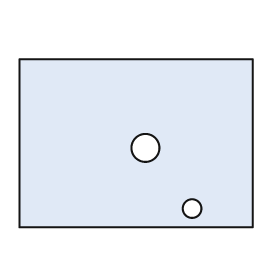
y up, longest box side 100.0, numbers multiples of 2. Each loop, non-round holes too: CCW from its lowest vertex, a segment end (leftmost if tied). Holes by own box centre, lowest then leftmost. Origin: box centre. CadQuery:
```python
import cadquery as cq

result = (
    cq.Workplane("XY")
    .moveTo(-50.0, -36.0)
    .lineTo(50.0, -36.0)
    .lineTo(50.0, 36.0)
    .lineTo(-50.0, 36.0)
    .close()
    .moveTo(24.0, -28.0)
    .circle(4.0)
    .moveTo(4.0, -2.0)
    .circle(6.0)
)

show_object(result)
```